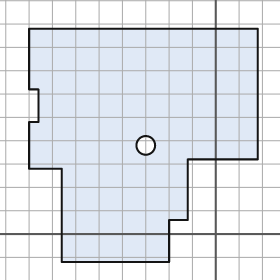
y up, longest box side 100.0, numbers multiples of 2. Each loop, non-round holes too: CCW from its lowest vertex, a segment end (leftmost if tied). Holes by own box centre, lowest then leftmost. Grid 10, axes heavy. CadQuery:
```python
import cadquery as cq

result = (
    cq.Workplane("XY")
    .moveTo(-66.0, -12.0)
    .lineTo(-20.0, -12.0)
    .lineTo(-20.0, 6.0)
    .lineTo(-12.0, 6.0)
    .lineTo(-12.0, 32.0)
    .lineTo(18.0, 32.0)
    .lineTo(18.0, 88.0)
    .lineTo(-80.0, 88.0)
    .lineTo(-80.0, 62.0)
    .lineTo(-76.0, 62.0)
    .lineTo(-76.0, 48.0)
    .lineTo(-80.0, 48.0)
    .lineTo(-80.0, 28.0)
    .lineTo(-66.0, 28.0)
    .close()
    .moveTo(-30.0, 38.0)
    .circle(4.0)
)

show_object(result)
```